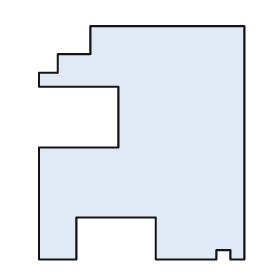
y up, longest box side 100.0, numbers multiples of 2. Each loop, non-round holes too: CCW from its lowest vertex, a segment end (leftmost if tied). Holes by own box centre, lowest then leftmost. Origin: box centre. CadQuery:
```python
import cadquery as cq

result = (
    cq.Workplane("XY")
    .moveTo(-44.0, -50.0)
    .lineTo(-28.0, -50.0)
    .lineTo(-28.0, -32.0)
    .lineTo(6.0, -32.0)
    .lineTo(6.0, -50.0)
    .lineTo(32.0, -50.0)
    .lineTo(32.0, -46.0)
    .lineTo(38.0, -46.0)
    .lineTo(38.0, -50.0)
    .lineTo(44.0, -50.0)
    .lineTo(44.0, 50.0)
    .lineTo(-22.0, 50.0)
    .lineTo(-22.0, 38.0)
    .lineTo(-36.0, 38.0)
    .lineTo(-36.0, 30.0)
    .lineTo(-44.0, 30.0)
    .lineTo(-44.0, 24.0)
    .lineTo(-10.0, 24.0)
    .lineTo(-10.0, -2.0)
    .lineTo(-44.0, -2.0)
    .close()
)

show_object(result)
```